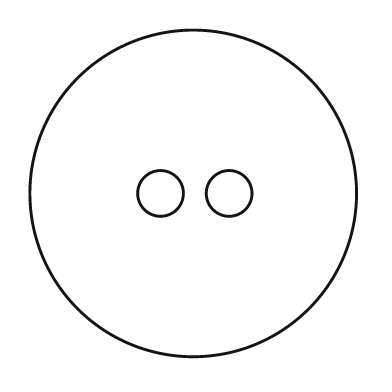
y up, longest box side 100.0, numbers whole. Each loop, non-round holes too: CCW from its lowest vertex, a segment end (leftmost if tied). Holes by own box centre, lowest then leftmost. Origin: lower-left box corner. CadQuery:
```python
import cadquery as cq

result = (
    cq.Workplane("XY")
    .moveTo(50.0, 50.0)
    .circle(50.0)
    .moveTo(40.0, 50.0)
    .circle(7.0)
    .moveTo(61.0, 50.0)
    .circle(7.0)
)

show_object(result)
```